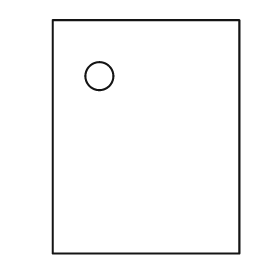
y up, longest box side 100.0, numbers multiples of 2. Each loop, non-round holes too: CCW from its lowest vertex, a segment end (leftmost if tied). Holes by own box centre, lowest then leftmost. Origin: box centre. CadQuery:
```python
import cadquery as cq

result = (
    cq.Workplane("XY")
    .moveTo(-40.0, -50.0)
    .lineTo(40.0, -50.0)
    .lineTo(40.0, 50.0)
    .lineTo(-40.0, 50.0)
    .close()
    .moveTo(-20.0, 26.0)
    .circle(6.0)
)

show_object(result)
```